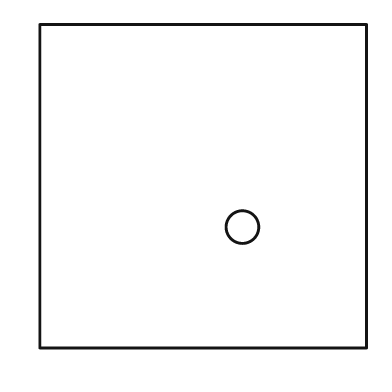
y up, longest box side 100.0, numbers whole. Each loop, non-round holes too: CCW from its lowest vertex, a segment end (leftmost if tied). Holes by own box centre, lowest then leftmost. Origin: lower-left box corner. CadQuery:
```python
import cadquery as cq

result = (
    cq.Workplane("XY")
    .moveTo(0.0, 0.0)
    .lineTo(100.0, 0.0)
    .lineTo(100.0, 99.0)
    .lineTo(0.0, 99.0)
    .close()
    .moveTo(62.0, 37.0)
    .circle(5.0)
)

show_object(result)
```